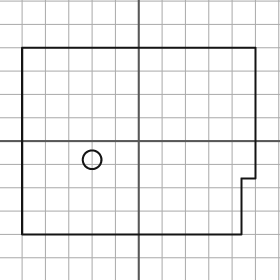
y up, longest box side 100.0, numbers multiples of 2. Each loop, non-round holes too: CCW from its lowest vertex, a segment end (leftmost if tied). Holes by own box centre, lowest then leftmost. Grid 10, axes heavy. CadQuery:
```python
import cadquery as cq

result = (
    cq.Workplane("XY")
    .moveTo(-50.0, -40.0)
    .lineTo(44.0, -40.0)
    .lineTo(44.0, -16.0)
    .lineTo(50.0, -16.0)
    .lineTo(50.0, 40.0)
    .lineTo(-50.0, 40.0)
    .close()
    .moveTo(-20.0, -8.0)
    .circle(4.0)
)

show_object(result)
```